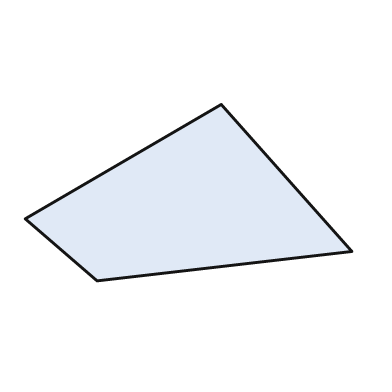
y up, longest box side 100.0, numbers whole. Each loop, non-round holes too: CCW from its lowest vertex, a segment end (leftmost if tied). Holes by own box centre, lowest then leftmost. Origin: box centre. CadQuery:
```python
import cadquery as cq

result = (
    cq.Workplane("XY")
    .moveTo(-28.0, -27.0)
    .lineTo(50.0, -18.0)
    .lineTo(10.0, 27.0)
    .lineTo(-50.0, -8.0)
    .close()
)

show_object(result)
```